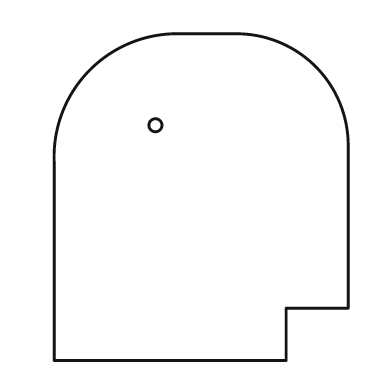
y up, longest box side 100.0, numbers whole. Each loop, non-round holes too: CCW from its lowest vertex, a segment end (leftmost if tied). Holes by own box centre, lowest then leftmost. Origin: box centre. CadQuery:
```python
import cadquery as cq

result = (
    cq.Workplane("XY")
    .moveTo(-45.0, -50.0)
    .lineTo(26.0, -50.0)
    .lineTo(26.0, -34.0)
    .lineTo(45.0, -34.0)
    .lineTo(45.0, 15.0)
    .threePointArc((35.0, 40.0), (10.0, 50.0))
    .lineTo(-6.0, 50.0)
    .threePointArc((-34.0, 39.0), (-45.0, 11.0))
    .close()
    .moveTo(-14.0, 22.0)
    .circle(2.0)
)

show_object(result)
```